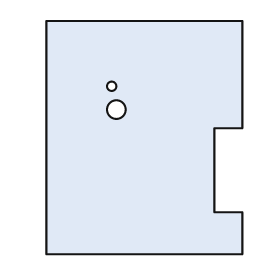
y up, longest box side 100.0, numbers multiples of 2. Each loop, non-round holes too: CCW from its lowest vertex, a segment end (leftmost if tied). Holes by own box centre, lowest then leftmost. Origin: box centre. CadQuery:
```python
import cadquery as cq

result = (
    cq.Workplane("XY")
    .moveTo(-42.0, -50.0)
    .lineTo(42.0, -50.0)
    .lineTo(42.0, -32.0)
    .lineTo(30.0, -32.0)
    .lineTo(30.0, 4.0)
    .lineTo(42.0, 4.0)
    .lineTo(42.0, 50.0)
    .lineTo(-42.0, 50.0)
    .close()
    .moveTo(-12.0, 12.0)
    .circle(4.0)
    .moveTo(-14.0, 22.0)
    .circle(2.0)
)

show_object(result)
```